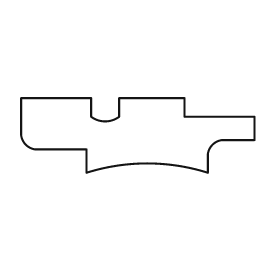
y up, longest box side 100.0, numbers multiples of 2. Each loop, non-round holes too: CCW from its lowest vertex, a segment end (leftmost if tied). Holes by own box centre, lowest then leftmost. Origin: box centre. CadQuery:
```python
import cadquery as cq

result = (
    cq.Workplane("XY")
    .moveTo(-22.0, -16.0)
    .threePointArc((4.0, -12.0), (30.0, -16.0))
    .lineTo(30.0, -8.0)
    .threePointArc((32.0, -4.0), (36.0, -2.0))
    .lineTo(50.0, -2.0)
    .lineTo(50.0, 8.0)
    .lineTo(20.0, 8.0)
    .lineTo(20.0, 16.0)
    .lineTo(-8.0, 16.0)
    .lineTo(-8.0, 8.0)
    .threePointArc((-14.0, 6.0), (-20.0, 8.0))
    .lineTo(-20.0, 16.0)
    .lineTo(-50.0, 16.0)
    .lineTo(-50.0, 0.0)
    .threePointArc((-48.0, -4.0), (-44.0, -6.0))
    .lineTo(-22.0, -6.0)
    .close()
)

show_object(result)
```